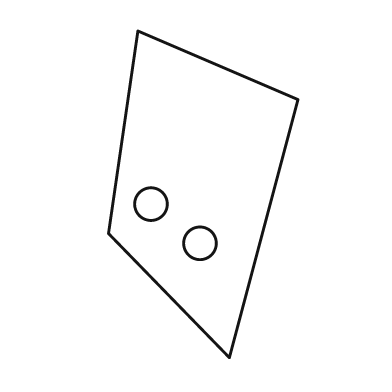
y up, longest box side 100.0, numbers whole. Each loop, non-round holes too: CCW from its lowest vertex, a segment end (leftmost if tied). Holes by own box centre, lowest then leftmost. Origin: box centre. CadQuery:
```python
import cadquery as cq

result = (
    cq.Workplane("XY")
    .moveTo(8.0, -50.0)
    .lineTo(29.0, 29.0)
    .lineTo(-20.0, 50.0)
    .lineTo(-29.0, -12.0)
    .close()
    .moveTo(-1.0, -15.0)
    .circle(5.0)
    .moveTo(-16.0, -3.0)
    .circle(5.0)
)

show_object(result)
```